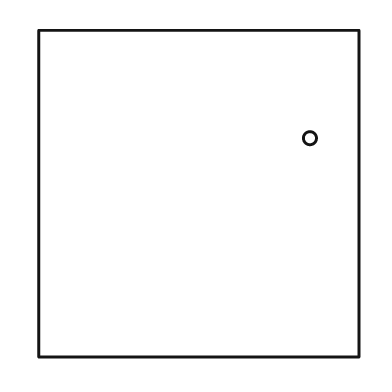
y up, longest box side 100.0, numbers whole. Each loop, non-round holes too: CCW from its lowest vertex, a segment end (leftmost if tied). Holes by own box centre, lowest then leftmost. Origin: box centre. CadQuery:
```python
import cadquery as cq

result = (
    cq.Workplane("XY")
    .moveTo(-49.0, -50.0)
    .lineTo(49.0, -50.0)
    .lineTo(49.0, 50.0)
    .lineTo(-49.0, 50.0)
    .close()
    .moveTo(34.0, 17.0)
    .circle(2.0)
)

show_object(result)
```